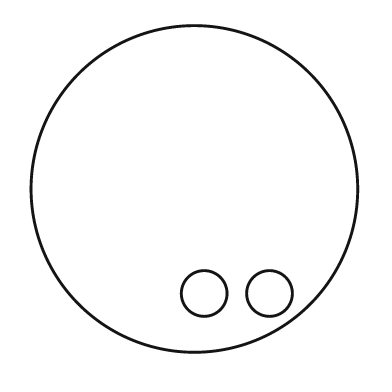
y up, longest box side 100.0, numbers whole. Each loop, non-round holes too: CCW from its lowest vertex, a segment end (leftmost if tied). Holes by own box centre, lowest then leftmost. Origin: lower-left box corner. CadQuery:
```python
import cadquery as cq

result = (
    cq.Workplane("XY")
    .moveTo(50.0, 50.0)
    .circle(50.0)
    .moveTo(53.0, 18.0)
    .circle(7.0)
    .moveTo(73.0, 18.0)
    .circle(7.0)
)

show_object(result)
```